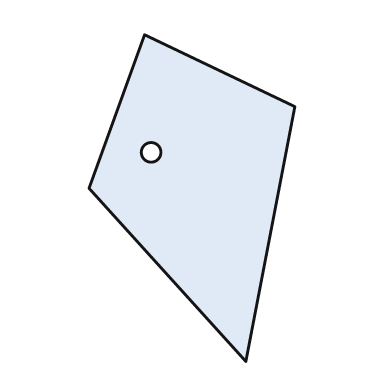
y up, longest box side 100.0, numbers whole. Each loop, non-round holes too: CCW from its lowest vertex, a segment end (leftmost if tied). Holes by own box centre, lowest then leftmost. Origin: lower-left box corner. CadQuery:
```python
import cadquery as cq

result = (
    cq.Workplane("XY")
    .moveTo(48.0, 0.0)
    .lineTo(63.0, 78.0)
    .lineTo(17.0, 100.0)
    .lineTo(0.0, 53.0)
    .close()
    .moveTo(19.0, 64.0)
    .circle(3.0)
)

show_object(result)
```